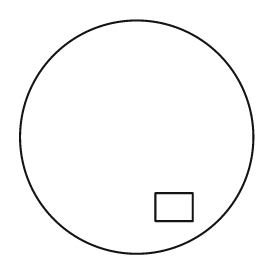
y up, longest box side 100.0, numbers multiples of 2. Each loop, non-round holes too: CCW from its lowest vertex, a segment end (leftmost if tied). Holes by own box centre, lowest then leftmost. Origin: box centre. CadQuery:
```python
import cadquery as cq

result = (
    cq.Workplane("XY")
    .moveTo(0.0, 0.0)
    .circle(50.0)
    .moveTo(8.0, -36.0)
    .lineTo(24.0, -36.0)
    .lineTo(24.0, -24.0)
    .lineTo(8.0, -24.0)
    .close()
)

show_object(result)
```